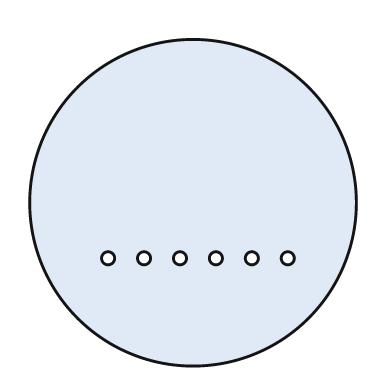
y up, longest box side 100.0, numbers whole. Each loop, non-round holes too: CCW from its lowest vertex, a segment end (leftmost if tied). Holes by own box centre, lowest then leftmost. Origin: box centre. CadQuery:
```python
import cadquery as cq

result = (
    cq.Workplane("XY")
    .moveTo(0.0, 0.0)
    .circle(50.0)
    .moveTo(-26.0, -17.0)
    .circle(2.0)
    .moveTo(-15.0, -17.0)
    .circle(2.0)
    .moveTo(-4.0, -17.0)
    .circle(2.0)
    .moveTo(7.0, -17.0)
    .circle(2.0)
    .moveTo(18.0, -17.0)
    .circle(2.0)
    .moveTo(29.0, -17.0)
    .circle(2.0)
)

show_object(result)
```